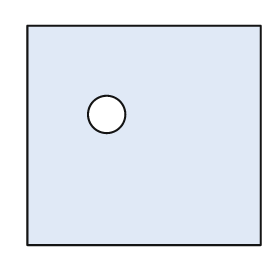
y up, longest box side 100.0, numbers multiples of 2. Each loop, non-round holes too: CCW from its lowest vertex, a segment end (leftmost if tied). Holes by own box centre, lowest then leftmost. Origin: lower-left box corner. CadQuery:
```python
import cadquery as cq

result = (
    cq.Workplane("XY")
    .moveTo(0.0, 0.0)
    .lineTo(100.0, 0.0)
    .lineTo(100.0, 94.0)
    .lineTo(0.0, 94.0)
    .close()
    .moveTo(34.0, 56.0)
    .circle(8.0)
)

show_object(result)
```